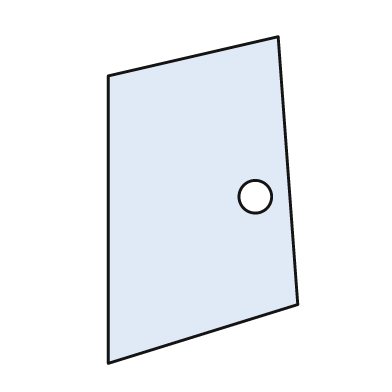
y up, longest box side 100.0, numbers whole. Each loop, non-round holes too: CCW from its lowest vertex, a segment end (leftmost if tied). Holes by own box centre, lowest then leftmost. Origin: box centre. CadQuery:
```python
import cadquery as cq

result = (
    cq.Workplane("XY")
    .moveTo(-29.0, -50.0)
    .lineTo(29.0, -32.0)
    .lineTo(23.0, 50.0)
    .lineTo(-29.0, 38.0)
    .close()
    .moveTo(16.0, 1.0)
    .circle(5.0)
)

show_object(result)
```